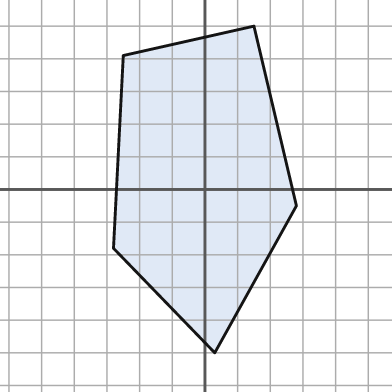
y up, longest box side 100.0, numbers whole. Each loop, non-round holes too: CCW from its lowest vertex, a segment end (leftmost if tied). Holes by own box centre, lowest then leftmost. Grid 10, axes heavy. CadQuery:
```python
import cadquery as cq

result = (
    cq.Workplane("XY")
    .moveTo(3.0, -50.0)
    .lineTo(28.0, -5.0)
    .lineTo(15.0, 50.0)
    .lineTo(-25.0, 41.0)
    .lineTo(-28.0, -18.0)
    .close()
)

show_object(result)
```